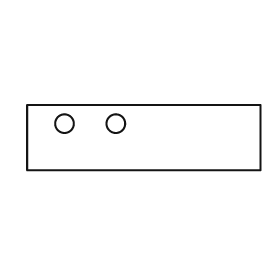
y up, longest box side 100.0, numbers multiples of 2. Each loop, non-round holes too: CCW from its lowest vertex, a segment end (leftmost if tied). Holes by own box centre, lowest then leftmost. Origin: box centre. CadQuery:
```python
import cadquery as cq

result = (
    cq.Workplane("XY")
    .moveTo(-50.0, -14.0)
    .lineTo(50.0, -14.0)
    .lineTo(50.0, 14.0)
    .lineTo(-50.0, 14.0)
    .close()
    .moveTo(-34.0, 6.0)
    .circle(4.0)
    .moveTo(-12.0, 6.0)
    .circle(4.0)
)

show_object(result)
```